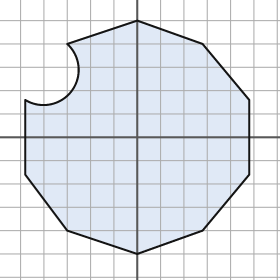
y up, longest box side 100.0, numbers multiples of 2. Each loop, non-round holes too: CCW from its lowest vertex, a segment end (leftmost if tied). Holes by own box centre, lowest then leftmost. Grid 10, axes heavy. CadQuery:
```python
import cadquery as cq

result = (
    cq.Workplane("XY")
    .moveTo(0.0, -50.0)
    .lineTo(28.0, -40.0)
    .lineTo(48.0, -16.0)
    .lineTo(48.0, 16.0)
    .lineTo(28.0, 40.0)
    .lineTo(0.0, 50.0)
    .lineTo(-30.0, 40.0)
    .threePointArc((-28.0, 20.0), (-48.0, 16.0))
    .lineTo(-48.0, -16.0)
    .lineTo(-30.0, -40.0)
    .close()
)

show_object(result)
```